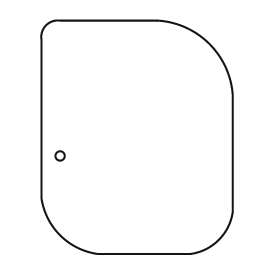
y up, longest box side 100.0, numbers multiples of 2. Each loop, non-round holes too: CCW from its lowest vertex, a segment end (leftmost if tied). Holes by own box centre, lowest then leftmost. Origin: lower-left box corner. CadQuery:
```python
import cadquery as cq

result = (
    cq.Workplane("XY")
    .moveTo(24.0, 0.0)
    .lineTo(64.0, 0.0)
    .threePointArc((76.0, 6.0), (82.0, 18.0))
    .lineTo(82.0, 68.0)
    .threePointArc((72.0, 90.0), (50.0, 100.0))
    .lineTo(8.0, 100.0)
    .threePointArc((2.0, 98.0), (0.0, 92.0))
    .lineTo(0.0, 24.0)
    .threePointArc((8.0, 8.0), (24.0, 0.0))
    .close()
    .moveTo(8.0, 42.0)
    .circle(2.0)
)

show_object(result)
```